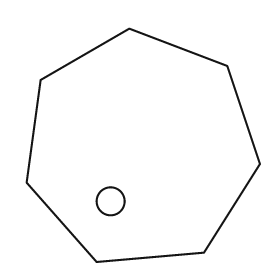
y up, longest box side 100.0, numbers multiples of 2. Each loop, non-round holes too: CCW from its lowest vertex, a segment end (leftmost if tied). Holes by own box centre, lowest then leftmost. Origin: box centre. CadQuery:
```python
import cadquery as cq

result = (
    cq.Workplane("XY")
    .moveTo(-20.0, -50.0)
    .lineTo(26.0, -46.0)
    .lineTo(50.0, -8.0)
    .lineTo(36.0, 34.0)
    .lineTo(-6.0, 50.0)
    .lineTo(-44.0, 28.0)
    .lineTo(-50.0, -16.0)
    .close()
    .moveTo(-14.0, -24.0)
    .circle(6.0)
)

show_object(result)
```